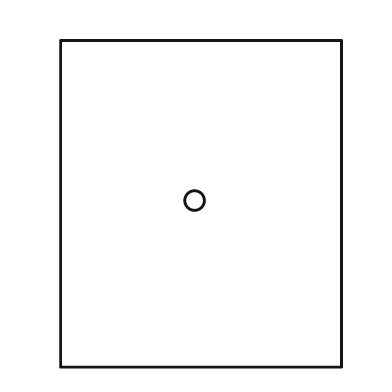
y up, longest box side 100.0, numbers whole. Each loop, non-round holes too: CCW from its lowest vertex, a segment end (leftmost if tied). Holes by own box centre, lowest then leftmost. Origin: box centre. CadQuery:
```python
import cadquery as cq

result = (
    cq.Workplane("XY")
    .moveTo(-43.0, -50.0)
    .lineTo(43.0, -50.0)
    .lineTo(43.0, 50.0)
    .lineTo(-43.0, 50.0)
    .close()
    .moveTo(-2.0, 1.0)
    .circle(3.0)
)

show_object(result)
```